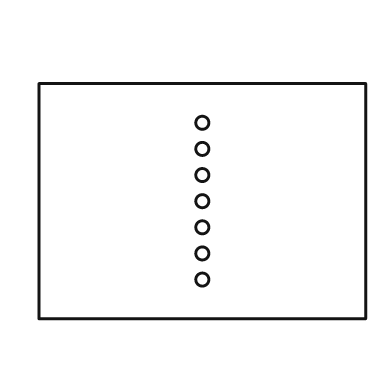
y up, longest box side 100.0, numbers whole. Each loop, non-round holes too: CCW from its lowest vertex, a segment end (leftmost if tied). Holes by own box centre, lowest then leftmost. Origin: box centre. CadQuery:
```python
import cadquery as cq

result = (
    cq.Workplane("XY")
    .moveTo(-50.0, -36.0)
    .lineTo(50.0, -36.0)
    .lineTo(50.0, 36.0)
    .lineTo(-50.0, 36.0)
    .close()
    .moveTo(0.0, -24.0)
    .circle(2.0)
    .moveTo(0.0, -16.0)
    .circle(2.0)
    .moveTo(0.0, -8.0)
    .circle(2.0)
    .moveTo(0.0, 0.0)
    .circle(2.0)
    .moveTo(0.0, 8.0)
    .circle(2.0)
    .moveTo(0.0, 16.0)
    .circle(2.0)
    .moveTo(0.0, 24.0)
    .circle(2.0)
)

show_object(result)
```